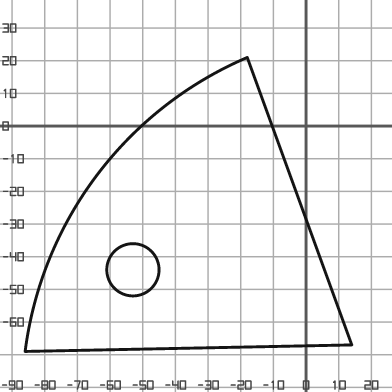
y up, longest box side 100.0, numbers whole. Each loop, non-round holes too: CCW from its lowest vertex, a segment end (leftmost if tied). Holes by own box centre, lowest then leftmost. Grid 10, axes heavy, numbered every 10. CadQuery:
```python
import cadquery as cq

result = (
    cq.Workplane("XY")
    .moveTo(-86.0, -69.0)
    .lineTo(14.0, -67.0)
    .lineTo(-18.0, 21.0)
    .threePointArc((-64.0, -15.0), (-86.0, -69.0))
    .close()
    .moveTo(-53.0, -44.0)
    .circle(8.0)
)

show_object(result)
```